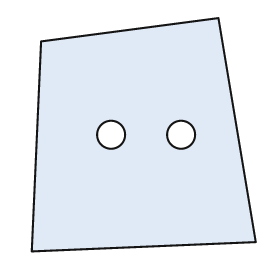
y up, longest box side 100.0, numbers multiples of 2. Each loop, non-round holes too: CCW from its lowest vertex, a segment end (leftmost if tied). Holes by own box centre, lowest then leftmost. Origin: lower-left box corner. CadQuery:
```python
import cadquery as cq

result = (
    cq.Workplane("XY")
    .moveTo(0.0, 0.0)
    .lineTo(96.0, 4.0)
    .lineTo(80.0, 100.0)
    .lineTo(4.0, 90.0)
    .close()
    .moveTo(34.0, 50.0)
    .circle(6.0)
    .moveTo(64.0, 50.0)
    .circle(6.0)
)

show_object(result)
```